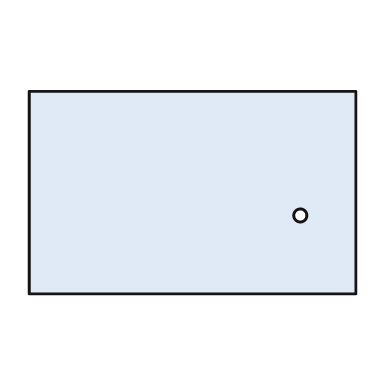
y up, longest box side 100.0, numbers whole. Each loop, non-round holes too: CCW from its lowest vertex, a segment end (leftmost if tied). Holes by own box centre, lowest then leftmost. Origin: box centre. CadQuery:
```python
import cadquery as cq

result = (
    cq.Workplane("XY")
    .moveTo(-50.0, -31.0)
    .lineTo(50.0, -31.0)
    .lineTo(50.0, 31.0)
    .lineTo(-50.0, 31.0)
    .close()
    .moveTo(33.0, -7.0)
    .circle(2.0)
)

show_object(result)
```